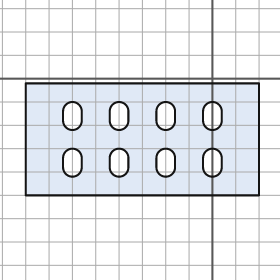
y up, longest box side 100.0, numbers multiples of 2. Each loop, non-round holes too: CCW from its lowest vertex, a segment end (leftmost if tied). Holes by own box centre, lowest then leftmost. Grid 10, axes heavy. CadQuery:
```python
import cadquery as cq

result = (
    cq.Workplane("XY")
    .moveTo(-80.0, -50.0)
    .lineTo(20.0, -50.0)
    .lineTo(20.0, -2.0)
    .lineTo(-80.0, -2.0)
    .close()
    .moveTo(-64.0, -38.0)
    .threePointArc((-60.0, -42.0), (-56.0, -38.0))
    .lineTo(-56.0, -34.0)
    .threePointArc((-60.0, -30.0), (-64.0, -34.0))
    .close()
    .moveTo(-44.0, -38.0)
    .threePointArc((-40.0, -42.0), (-36.0, -38.0))
    .lineTo(-36.0, -34.0)
    .threePointArc((-40.0, -30.0), (-44.0, -34.0))
    .close()
    .moveTo(-24.0, -38.0)
    .threePointArc((-20.0, -42.0), (-16.0, -38.0))
    .lineTo(-16.0, -34.0)
    .threePointArc((-20.0, -30.0), (-24.0, -34.0))
    .close()
    .moveTo(-4.0, -38.0)
    .threePointArc((0.0, -42.0), (4.0, -38.0))
    .lineTo(4.0, -34.0)
    .threePointArc((0.0, -30.0), (-4.0, -34.0))
    .close()
    .moveTo(-64.0, -18.0)
    .threePointArc((-60.0, -22.0), (-56.0, -18.0))
    .lineTo(-56.0, -14.0)
    .threePointArc((-60.0, -10.0), (-64.0, -14.0))
    .close()
    .moveTo(-44.0, -18.0)
    .threePointArc((-40.0, -22.0), (-36.0, -18.0))
    .lineTo(-36.0, -14.0)
    .threePointArc((-40.0, -10.0), (-44.0, -14.0))
    .close()
    .moveTo(-24.0, -18.0)
    .threePointArc((-20.0, -22.0), (-16.0, -18.0))
    .lineTo(-16.0, -14.0)
    .threePointArc((-20.0, -10.0), (-24.0, -14.0))
    .close()
    .moveTo(-4.0, -18.0)
    .threePointArc((0.0, -22.0), (4.0, -18.0))
    .lineTo(4.0, -14.0)
    .threePointArc((0.0, -10.0), (-4.0, -14.0))
    .close()
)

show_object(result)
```